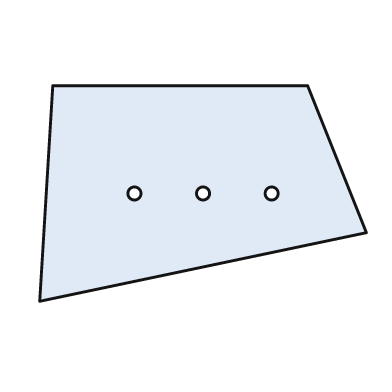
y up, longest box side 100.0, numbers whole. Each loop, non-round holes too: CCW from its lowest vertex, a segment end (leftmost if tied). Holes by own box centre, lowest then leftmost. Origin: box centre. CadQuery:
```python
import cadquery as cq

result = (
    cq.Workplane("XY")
    .moveTo(-50.0, -33.0)
    .lineTo(50.0, -12.0)
    .lineTo(32.0, 33.0)
    .lineTo(-46.0, 33.0)
    .close()
    .moveTo(-21.0, 0.0)
    .circle(2.0)
    .moveTo(0.0, 0.0)
    .circle(2.0)
    .moveTo(21.0, 0.0)
    .circle(2.0)
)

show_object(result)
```